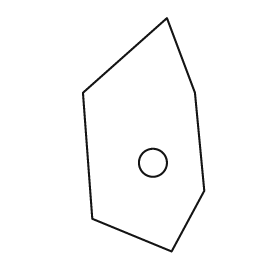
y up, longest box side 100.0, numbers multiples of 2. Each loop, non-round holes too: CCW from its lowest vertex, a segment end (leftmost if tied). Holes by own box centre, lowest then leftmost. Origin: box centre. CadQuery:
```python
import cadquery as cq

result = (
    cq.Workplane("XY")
    .moveTo(12.0, -50.0)
    .lineTo(26.0, -24.0)
    .lineTo(22.0, 18.0)
    .lineTo(10.0, 50.0)
    .lineTo(-26.0, 18.0)
    .lineTo(-22.0, -36.0)
    .close()
    .moveTo(4.0, -12.0)
    .circle(6.0)
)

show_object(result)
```